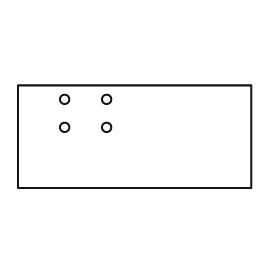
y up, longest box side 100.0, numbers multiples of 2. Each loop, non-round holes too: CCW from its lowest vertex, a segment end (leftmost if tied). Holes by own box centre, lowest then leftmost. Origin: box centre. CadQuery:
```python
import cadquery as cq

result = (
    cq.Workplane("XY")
    .moveTo(-50.0, -22.0)
    .lineTo(50.0, -22.0)
    .lineTo(50.0, 22.0)
    .lineTo(-50.0, 22.0)
    .close()
    .moveTo(-30.0, 4.0)
    .circle(2.0)
    .moveTo(-12.0, 4.0)
    .circle(2.0)
    .moveTo(-30.0, 16.0)
    .circle(2.0)
    .moveTo(-12.0, 16.0)
    .circle(2.0)
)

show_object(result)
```